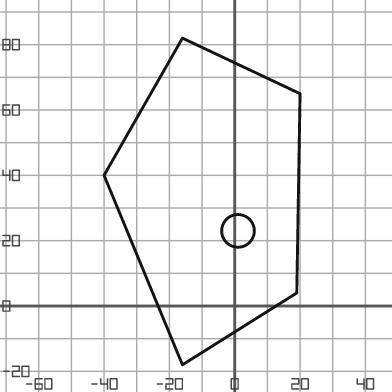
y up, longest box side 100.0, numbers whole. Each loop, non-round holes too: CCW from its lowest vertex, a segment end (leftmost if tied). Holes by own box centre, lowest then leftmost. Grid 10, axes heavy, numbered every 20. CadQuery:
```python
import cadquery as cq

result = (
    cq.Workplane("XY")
    .moveTo(-16.0, -18.0)
    .lineTo(19.0, 4.0)
    .lineTo(20.0, 65.0)
    .lineTo(-16.0, 82.0)
    .lineTo(-40.0, 40.0)
    .close()
    .moveTo(1.0, 23.0)
    .circle(5.0)
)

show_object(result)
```